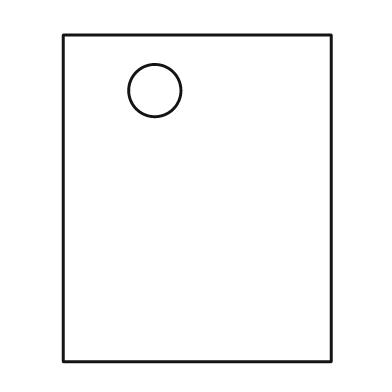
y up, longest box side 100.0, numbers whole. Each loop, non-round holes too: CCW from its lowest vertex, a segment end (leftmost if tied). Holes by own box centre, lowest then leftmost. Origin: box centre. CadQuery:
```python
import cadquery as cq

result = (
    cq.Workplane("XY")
    .moveTo(-41.0, -50.0)
    .lineTo(41.0, -50.0)
    .lineTo(41.0, 50.0)
    .lineTo(-41.0, 50.0)
    .close()
    .moveTo(-13.0, 33.0)
    .circle(8.0)
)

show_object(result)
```